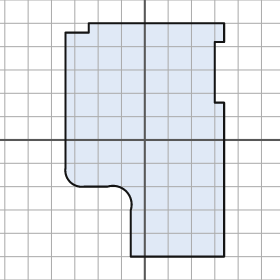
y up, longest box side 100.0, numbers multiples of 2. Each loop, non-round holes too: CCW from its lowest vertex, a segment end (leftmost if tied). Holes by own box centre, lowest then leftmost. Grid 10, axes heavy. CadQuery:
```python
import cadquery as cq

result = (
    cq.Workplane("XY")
    .moveTo(-6.0, -50.0)
    .lineTo(34.0, -50.0)
    .lineTo(34.0, 16.0)
    .lineTo(30.0, 16.0)
    .lineTo(30.0, 42.0)
    .lineTo(34.0, 42.0)
    .lineTo(34.0, 50.0)
    .lineTo(-24.0, 50.0)
    .lineTo(-24.0, 46.0)
    .lineTo(-34.0, 46.0)
    .lineTo(-34.0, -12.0)
    .threePointArc((-32.0, -18.0), (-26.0, -20.0))
    .lineTo(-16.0, -20.0)
    .threePointArc((-8.0, -22.0), (-6.0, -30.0))
    .close()
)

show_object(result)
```